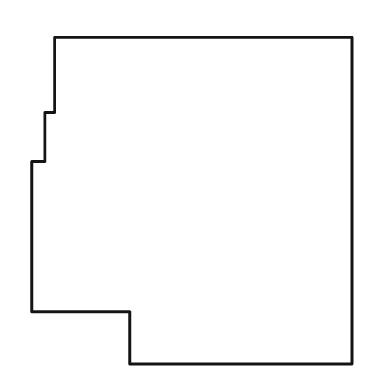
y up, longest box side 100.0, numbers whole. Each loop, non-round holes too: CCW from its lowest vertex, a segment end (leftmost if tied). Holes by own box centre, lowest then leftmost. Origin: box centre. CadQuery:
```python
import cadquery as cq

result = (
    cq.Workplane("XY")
    .moveTo(-19.0, -50.0)
    .lineTo(49.0, -50.0)
    .lineTo(49.0, 50.0)
    .lineTo(-42.0, 50.0)
    .lineTo(-42.0, 27.0)
    .lineTo(-45.0, 27.0)
    .lineTo(-45.0, 12.0)
    .lineTo(-49.0, 12.0)
    .lineTo(-49.0, -34.0)
    .lineTo(-19.0, -34.0)
    .close()
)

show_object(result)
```